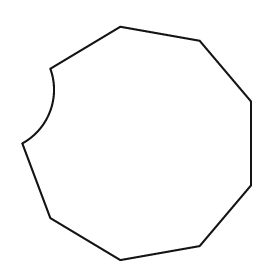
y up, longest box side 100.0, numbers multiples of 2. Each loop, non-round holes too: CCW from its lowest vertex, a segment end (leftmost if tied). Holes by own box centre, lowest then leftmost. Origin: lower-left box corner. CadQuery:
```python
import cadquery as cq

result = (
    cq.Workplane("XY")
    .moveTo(42.0, 0.0)
    .lineTo(76.0, 6.0)
    .lineTo(98.0, 32.0)
    .lineTo(98.0, 68.0)
    .lineTo(76.0, 94.0)
    .lineTo(42.0, 100.0)
    .lineTo(12.0, 82.0)
    .threePointArc((12.0, 64.0), (0.0, 50.0))
    .lineTo(12.0, 18.0)
    .close()
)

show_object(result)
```